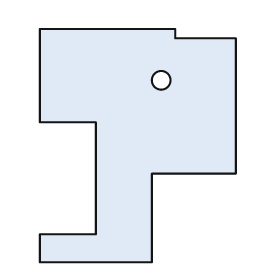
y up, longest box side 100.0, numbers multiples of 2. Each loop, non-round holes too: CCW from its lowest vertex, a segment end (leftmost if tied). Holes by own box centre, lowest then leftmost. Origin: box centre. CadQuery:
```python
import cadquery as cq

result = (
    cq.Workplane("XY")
    .moveTo(-42.0, -50.0)
    .lineTo(6.0, -50.0)
    .lineTo(6.0, -12.0)
    .lineTo(42.0, -12.0)
    .lineTo(42.0, 46.0)
    .lineTo(16.0, 46.0)
    .lineTo(16.0, 50.0)
    .lineTo(-42.0, 50.0)
    .lineTo(-42.0, 10.0)
    .lineTo(-18.0, 10.0)
    .lineTo(-18.0, -38.0)
    .lineTo(-42.0, -38.0)
    .close()
    .moveTo(10.0, 28.0)
    .circle(4.0)
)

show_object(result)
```